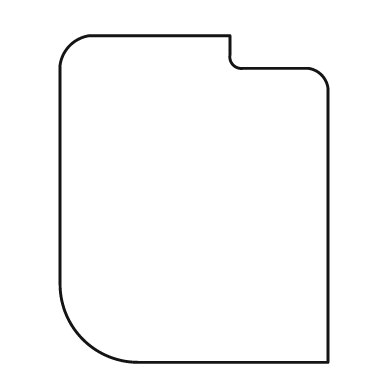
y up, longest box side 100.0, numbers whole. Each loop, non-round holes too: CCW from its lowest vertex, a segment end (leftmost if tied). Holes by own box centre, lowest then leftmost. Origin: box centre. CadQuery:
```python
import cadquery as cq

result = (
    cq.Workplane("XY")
    .moveTo(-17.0, -50.0)
    .lineTo(41.0, -50.0)
    .lineTo(41.0, 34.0)
    .threePointArc((39.0, 38.0), (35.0, 40.0))
    .lineTo(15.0, 40.0)
    .threePointArc((12.0, 41.0), (11.0, 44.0))
    .lineTo(11.0, 50.0)
    .lineTo(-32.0, 50.0)
    .threePointArc((-38.0, 47.0), (-41.0, 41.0))
    .lineTo(-41.0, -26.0)
    .threePointArc((-34.0, -43.0), (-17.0, -50.0))
    .close()
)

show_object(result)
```